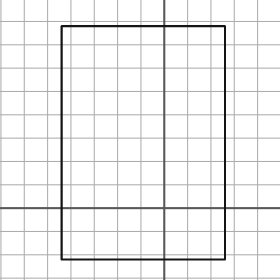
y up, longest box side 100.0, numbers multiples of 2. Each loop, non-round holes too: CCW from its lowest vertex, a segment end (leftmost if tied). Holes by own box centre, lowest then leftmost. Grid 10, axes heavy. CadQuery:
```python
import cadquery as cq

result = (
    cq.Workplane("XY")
    .moveTo(-44.0, -22.0)
    .lineTo(26.0, -22.0)
    .lineTo(26.0, 78.0)
    .lineTo(-44.0, 78.0)
    .close()
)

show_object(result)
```